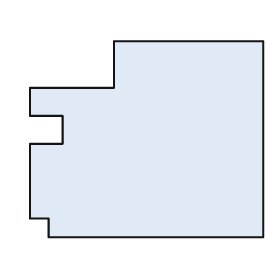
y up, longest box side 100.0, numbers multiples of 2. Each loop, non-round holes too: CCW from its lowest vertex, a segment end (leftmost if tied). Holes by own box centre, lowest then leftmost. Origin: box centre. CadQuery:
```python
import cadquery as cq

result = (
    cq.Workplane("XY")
    .moveTo(-42.0, -42.0)
    .lineTo(50.0, -42.0)
    .lineTo(50.0, 42.0)
    .lineTo(-14.0, 42.0)
    .lineTo(-14.0, 22.0)
    .lineTo(-50.0, 22.0)
    .lineTo(-50.0, 10.0)
    .lineTo(-36.0, 10.0)
    .lineTo(-36.0, -2.0)
    .lineTo(-50.0, -2.0)
    .lineTo(-50.0, -34.0)
    .lineTo(-42.0, -34.0)
    .close()
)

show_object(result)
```